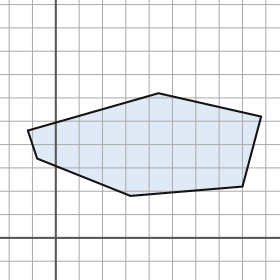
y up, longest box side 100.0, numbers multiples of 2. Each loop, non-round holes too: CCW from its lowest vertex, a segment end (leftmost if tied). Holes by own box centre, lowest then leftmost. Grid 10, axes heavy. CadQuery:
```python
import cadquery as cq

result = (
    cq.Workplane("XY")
    .moveTo(32.0, 18.0)
    .lineTo(80.0, 22.0)
    .lineTo(88.0, 52.0)
    .lineTo(44.0, 62.0)
    .lineTo(-12.0, 46.0)
    .lineTo(-8.0, 34.0)
    .close()
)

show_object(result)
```